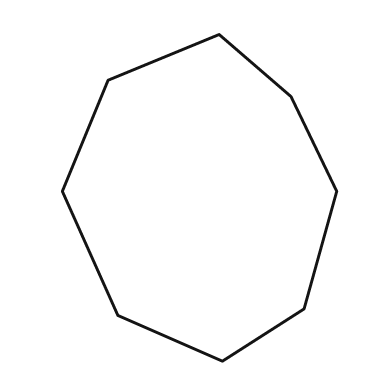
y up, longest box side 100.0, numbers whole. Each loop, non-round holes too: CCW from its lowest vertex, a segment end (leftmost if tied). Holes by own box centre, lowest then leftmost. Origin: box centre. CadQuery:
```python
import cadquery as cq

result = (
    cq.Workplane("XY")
    .moveTo(7.0, -50.0)
    .lineTo(32.0, -34.0)
    .lineTo(42.0, 2.0)
    .lineTo(28.0, 31.0)
    .lineTo(6.0, 50.0)
    .lineTo(-28.0, 36.0)
    .lineTo(-42.0, 2.0)
    .lineTo(-25.0, -36.0)
    .close()
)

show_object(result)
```